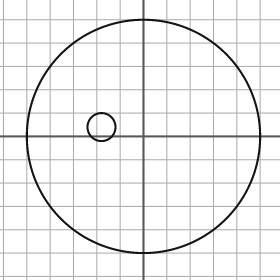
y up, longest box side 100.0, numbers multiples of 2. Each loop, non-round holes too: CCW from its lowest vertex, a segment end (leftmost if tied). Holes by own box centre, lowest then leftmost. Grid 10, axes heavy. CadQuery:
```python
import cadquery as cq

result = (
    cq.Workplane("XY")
    .moveTo(0.0, 0.0)
    .circle(50.0)
    .moveTo(-18.0, 4.0)
    .circle(6.0)
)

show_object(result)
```